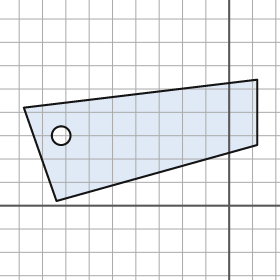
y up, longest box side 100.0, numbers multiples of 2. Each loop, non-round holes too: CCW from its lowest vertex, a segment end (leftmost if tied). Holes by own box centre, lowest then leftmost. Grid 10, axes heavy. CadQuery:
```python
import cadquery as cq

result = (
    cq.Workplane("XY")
    .moveTo(-74.0, 2.0)
    .lineTo(12.0, 26.0)
    .lineTo(12.0, 54.0)
    .lineTo(-88.0, 42.0)
    .close()
    .moveTo(-72.0, 30.0)
    .circle(4.0)
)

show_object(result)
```